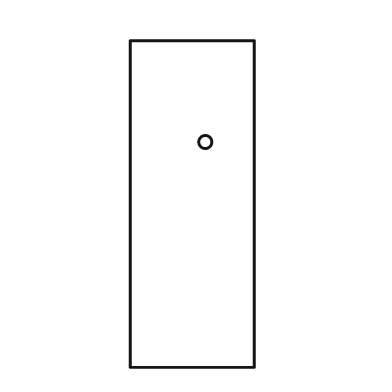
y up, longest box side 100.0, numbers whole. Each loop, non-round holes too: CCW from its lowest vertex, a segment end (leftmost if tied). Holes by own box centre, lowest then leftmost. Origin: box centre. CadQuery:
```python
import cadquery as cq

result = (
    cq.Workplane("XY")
    .moveTo(-19.0, -50.0)
    .lineTo(19.0, -50.0)
    .lineTo(19.0, 50.0)
    .lineTo(-19.0, 50.0)
    .close()
    .moveTo(4.0, 19.0)
    .circle(2.0)
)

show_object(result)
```